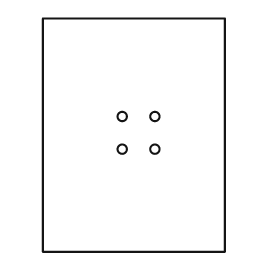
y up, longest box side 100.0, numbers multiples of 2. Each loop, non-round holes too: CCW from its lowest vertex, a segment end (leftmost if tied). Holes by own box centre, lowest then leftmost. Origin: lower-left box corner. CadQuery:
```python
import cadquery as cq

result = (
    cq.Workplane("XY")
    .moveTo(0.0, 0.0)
    .lineTo(78.0, 0.0)
    .lineTo(78.0, 100.0)
    .lineTo(0.0, 100.0)
    .close()
    .moveTo(34.0, 44.0)
    .circle(2.0)
    .moveTo(48.0, 44.0)
    .circle(2.0)
    .moveTo(34.0, 58.0)
    .circle(2.0)
    .moveTo(48.0, 58.0)
    .circle(2.0)
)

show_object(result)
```